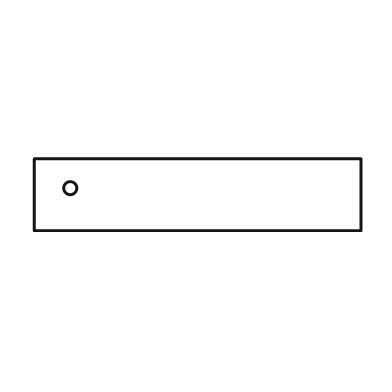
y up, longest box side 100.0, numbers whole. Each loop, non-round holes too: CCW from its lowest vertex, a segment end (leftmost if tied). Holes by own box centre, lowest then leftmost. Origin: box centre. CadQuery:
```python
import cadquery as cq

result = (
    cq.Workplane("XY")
    .moveTo(-50.0, -11.0)
    .lineTo(50.0, -11.0)
    .lineTo(50.0, 11.0)
    .lineTo(-50.0, 11.0)
    .close()
    .moveTo(-39.0, 2.0)
    .circle(2.0)
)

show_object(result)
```